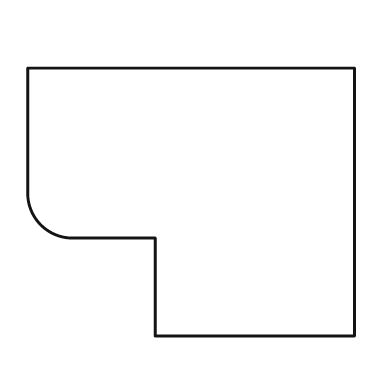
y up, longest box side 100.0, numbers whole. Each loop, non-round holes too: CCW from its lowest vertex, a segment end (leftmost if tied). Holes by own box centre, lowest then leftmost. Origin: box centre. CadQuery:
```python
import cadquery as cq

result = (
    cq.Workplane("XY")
    .moveTo(-11.0, -41.0)
    .lineTo(50.0, -41.0)
    .lineTo(50.0, 41.0)
    .lineTo(-50.0, 41.0)
    .lineTo(-50.0, 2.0)
    .threePointArc((-46.0, -7.0), (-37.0, -11.0))
    .lineTo(-11.0, -11.0)
    .close()
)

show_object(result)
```